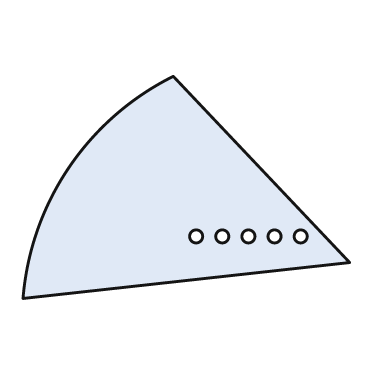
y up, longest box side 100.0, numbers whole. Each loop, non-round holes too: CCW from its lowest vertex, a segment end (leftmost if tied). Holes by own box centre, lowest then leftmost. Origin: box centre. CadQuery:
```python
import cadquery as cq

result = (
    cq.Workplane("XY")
    .moveTo(-50.0, -34.0)
    .lineTo(50.0, -23.0)
    .lineTo(-4.0, 34.0)
    .threePointArc((-36.0, 6.0), (-50.0, -34.0))
    .close()
    .moveTo(3.0, -15.0)
    .circle(2.0)
    .moveTo(11.0, -15.0)
    .circle(2.0)
    .moveTo(19.0, -15.0)
    .circle(2.0)
    .moveTo(27.0, -15.0)
    .circle(2.0)
    .moveTo(35.0, -15.0)
    .circle(2.0)
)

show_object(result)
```